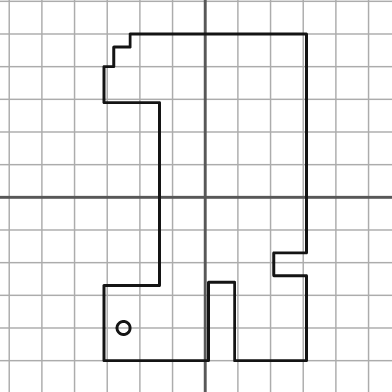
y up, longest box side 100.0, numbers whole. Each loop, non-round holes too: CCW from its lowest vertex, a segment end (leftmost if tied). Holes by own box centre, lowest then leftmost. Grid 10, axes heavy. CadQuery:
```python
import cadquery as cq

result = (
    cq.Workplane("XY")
    .moveTo(-31.0, -50.0)
    .lineTo(1.0, -50.0)
    .lineTo(1.0, -26.0)
    .lineTo(9.0, -26.0)
    .lineTo(9.0, -50.0)
    .lineTo(31.0, -50.0)
    .lineTo(31.0, -24.0)
    .lineTo(21.0, -24.0)
    .lineTo(21.0, -17.0)
    .lineTo(31.0, -17.0)
    .lineTo(31.0, 50.0)
    .lineTo(-23.0, 50.0)
    .lineTo(-23.0, 46.0)
    .lineTo(-28.0, 46.0)
    .lineTo(-28.0, 40.0)
    .lineTo(-31.0, 40.0)
    .lineTo(-31.0, 29.0)
    .lineTo(-14.0, 29.0)
    .lineTo(-14.0, -27.0)
    .lineTo(-31.0, -27.0)
    .close()
    .moveTo(-25.0, -40.0)
    .circle(2.0)
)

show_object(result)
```